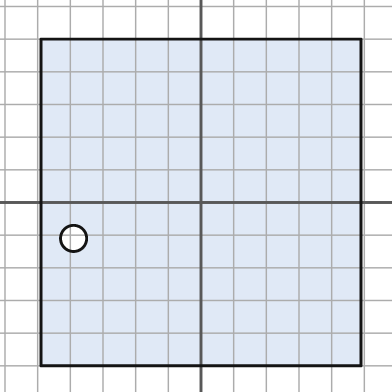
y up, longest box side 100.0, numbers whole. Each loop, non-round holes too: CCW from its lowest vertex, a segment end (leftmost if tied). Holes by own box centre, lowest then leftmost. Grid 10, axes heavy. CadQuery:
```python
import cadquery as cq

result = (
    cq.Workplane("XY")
    .moveTo(-49.0, -50.0)
    .lineTo(49.0, -50.0)
    .lineTo(49.0, 50.0)
    .lineTo(-49.0, 50.0)
    .close()
    .moveTo(-39.0, -11.0)
    .circle(4.0)
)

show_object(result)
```